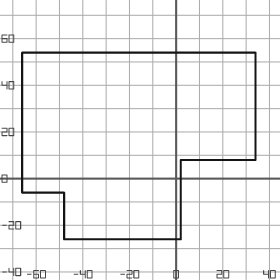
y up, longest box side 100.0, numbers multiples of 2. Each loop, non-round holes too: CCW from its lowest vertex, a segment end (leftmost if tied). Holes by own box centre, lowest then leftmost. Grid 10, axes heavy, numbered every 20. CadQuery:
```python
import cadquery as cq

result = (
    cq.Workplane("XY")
    .moveTo(-48.0, -26.0)
    .lineTo(2.0, -26.0)
    .lineTo(2.0, 8.0)
    .lineTo(34.0, 8.0)
    .lineTo(34.0, 54.0)
    .lineTo(-66.0, 54.0)
    .lineTo(-66.0, -6.0)
    .lineTo(-48.0, -6.0)
    .close()
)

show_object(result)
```